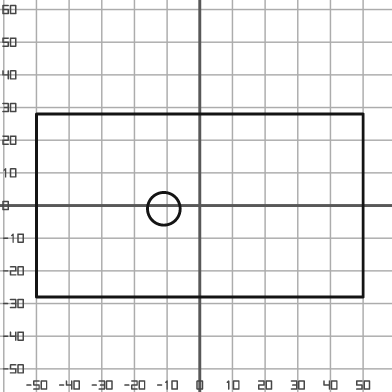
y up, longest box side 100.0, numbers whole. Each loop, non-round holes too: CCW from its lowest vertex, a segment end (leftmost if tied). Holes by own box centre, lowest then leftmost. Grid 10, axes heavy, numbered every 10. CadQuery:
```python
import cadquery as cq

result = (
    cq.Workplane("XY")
    .moveTo(-50.0, -28.0)
    .lineTo(50.0, -28.0)
    .lineTo(50.0, 28.0)
    .lineTo(-50.0, 28.0)
    .close()
    .moveTo(-11.0, -1.0)
    .circle(5.0)
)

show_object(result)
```